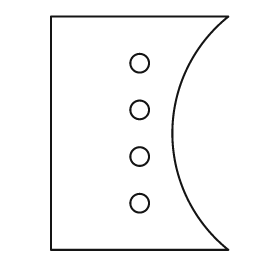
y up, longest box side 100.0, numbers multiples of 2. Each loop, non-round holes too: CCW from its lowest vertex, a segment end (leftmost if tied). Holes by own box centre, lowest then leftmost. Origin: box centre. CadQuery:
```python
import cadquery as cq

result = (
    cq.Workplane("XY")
    .moveTo(-38.0, -50.0)
    .lineTo(38.0, -50.0)
    .threePointArc((14.0, 0.0), (38.0, 50.0))
    .lineTo(-38.0, 50.0)
    .close()
    .moveTo(0.0, -30.0)
    .circle(4.0)
    .moveTo(0.0, -10.0)
    .circle(4.0)
    .moveTo(0.0, 10.0)
    .circle(4.0)
    .moveTo(0.0, 30.0)
    .circle(4.0)
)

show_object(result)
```